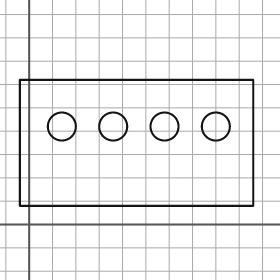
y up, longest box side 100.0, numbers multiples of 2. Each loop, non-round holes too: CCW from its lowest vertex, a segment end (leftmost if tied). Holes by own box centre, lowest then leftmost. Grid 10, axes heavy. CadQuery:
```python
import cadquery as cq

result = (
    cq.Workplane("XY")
    .moveTo(-4.0, 8.0)
    .lineTo(96.0, 8.0)
    .lineTo(96.0, 62.0)
    .lineTo(-4.0, 62.0)
    .close()
    .moveTo(14.0, 42.0)
    .circle(6.0)
    .moveTo(36.0, 42.0)
    .circle(6.0)
    .moveTo(58.0, 42.0)
    .circle(6.0)
    .moveTo(80.0, 42.0)
    .circle(6.0)
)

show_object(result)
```